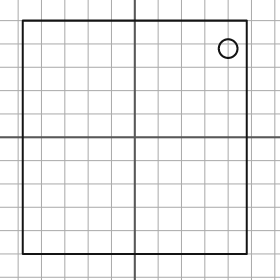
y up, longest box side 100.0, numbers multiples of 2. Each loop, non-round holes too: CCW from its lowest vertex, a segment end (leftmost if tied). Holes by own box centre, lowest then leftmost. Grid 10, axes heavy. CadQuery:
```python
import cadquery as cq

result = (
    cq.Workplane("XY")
    .moveTo(-48.0, -50.0)
    .lineTo(48.0, -50.0)
    .lineTo(48.0, 50.0)
    .lineTo(-48.0, 50.0)
    .close()
    .moveTo(40.0, 38.0)
    .circle(4.0)
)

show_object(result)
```